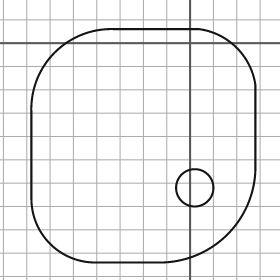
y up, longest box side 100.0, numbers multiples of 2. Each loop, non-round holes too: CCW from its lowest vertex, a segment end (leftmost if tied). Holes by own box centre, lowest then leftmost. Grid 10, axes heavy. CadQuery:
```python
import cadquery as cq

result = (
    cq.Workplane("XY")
    .moveTo(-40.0, -94.0)
    .lineTo(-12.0, -94.0)
    .threePointArc((16.0, -82.0), (28.0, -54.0))
    .lineTo(28.0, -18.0)
    .threePointArc((20.0, -2.0), (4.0, 6.0))
    .lineTo(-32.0, 6.0)
    .threePointArc((-58.0, -4.0), (-68.0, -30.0))
    .lineTo(-68.0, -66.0)
    .threePointArc((-60.0, -86.0), (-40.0, -94.0))
    .close()
    .moveTo(2.0, -62.0)
    .circle(8.0)
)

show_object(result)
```